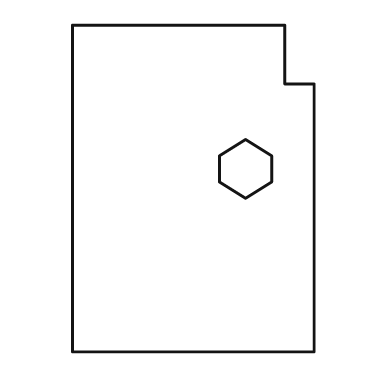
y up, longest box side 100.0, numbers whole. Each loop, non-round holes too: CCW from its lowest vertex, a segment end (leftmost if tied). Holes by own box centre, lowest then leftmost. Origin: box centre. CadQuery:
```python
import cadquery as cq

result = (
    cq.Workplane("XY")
    .moveTo(-37.0, -50.0)
    .lineTo(37.0, -50.0)
    .lineTo(37.0, 32.0)
    .lineTo(28.0, 32.0)
    .lineTo(28.0, 50.0)
    .lineTo(-37.0, 50.0)
    .close()
    .moveTo(16.0, -3.0)
    .lineTo(24.0, 2.0)
    .lineTo(24.0, 10.0)
    .lineTo(16.0, 15.0)
    .lineTo(8.0, 10.0)
    .lineTo(8.0, 2.0)
    .close()
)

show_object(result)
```